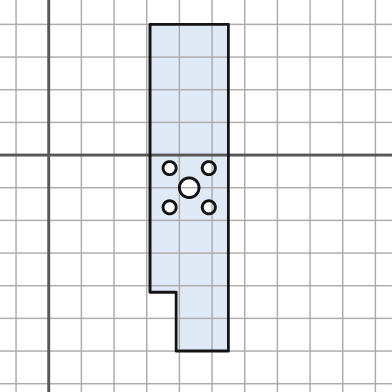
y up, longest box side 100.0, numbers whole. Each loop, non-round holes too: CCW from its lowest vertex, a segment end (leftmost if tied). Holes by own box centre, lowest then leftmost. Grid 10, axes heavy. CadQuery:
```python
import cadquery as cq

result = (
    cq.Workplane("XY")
    .moveTo(39.0, -60.0)
    .lineTo(55.0, -60.0)
    .lineTo(55.0, 40.0)
    .lineTo(31.0, 40.0)
    .lineTo(31.0, -42.0)
    .lineTo(39.0, -42.0)
    .close()
    .moveTo(37.0, -16.0)
    .circle(2.0)
    .moveTo(49.0, -16.0)
    .circle(2.0)
    .moveTo(43.0, -10.0)
    .circle(3.0)
    .moveTo(37.0, -4.0)
    .circle(2.0)
    .moveTo(49.0, -4.0)
    .circle(2.0)
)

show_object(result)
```